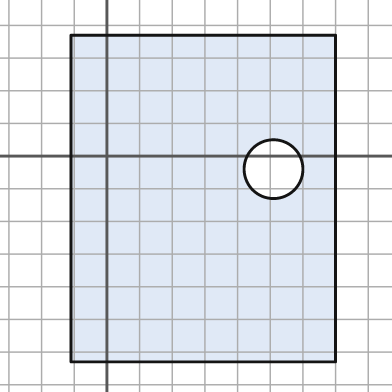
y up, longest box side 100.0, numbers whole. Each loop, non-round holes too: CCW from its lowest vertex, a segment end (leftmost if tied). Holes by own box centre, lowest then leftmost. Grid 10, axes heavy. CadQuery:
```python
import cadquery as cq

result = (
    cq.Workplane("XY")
    .moveTo(-11.0, -63.0)
    .lineTo(70.0, -63.0)
    .lineTo(70.0, 37.0)
    .lineTo(-11.0, 37.0)
    .close()
    .moveTo(51.0, -4.0)
    .circle(9.0)
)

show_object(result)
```